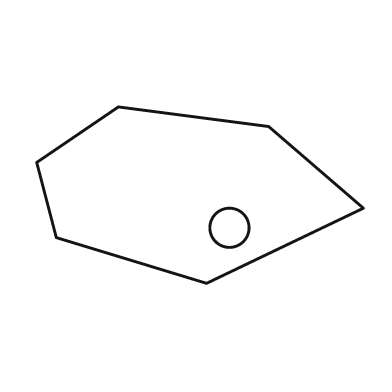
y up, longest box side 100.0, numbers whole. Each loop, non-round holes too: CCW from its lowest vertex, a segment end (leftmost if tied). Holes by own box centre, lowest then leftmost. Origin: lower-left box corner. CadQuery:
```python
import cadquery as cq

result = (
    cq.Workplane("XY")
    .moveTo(52.0, 0.0)
    .lineTo(100.0, 23.0)
    .lineTo(71.0, 48.0)
    .lineTo(25.0, 54.0)
    .lineTo(0.0, 37.0)
    .lineTo(6.0, 14.0)
    .close()
    .moveTo(59.0, 17.0)
    .circle(6.0)
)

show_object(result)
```